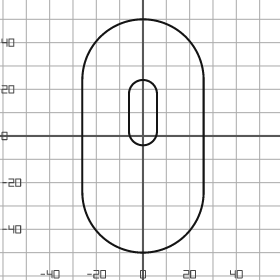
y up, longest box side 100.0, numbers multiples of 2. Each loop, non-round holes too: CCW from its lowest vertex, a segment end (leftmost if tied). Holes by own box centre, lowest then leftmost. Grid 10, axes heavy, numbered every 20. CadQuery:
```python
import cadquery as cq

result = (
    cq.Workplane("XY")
    .moveTo(-26.0, -24.0)
    .threePointArc((0.0, -50.0), (26.0, -24.0))
    .lineTo(26.0, 24.0)
    .threePointArc((0.0, 50.0), (-26.0, 24.0))
    .close()
    .moveTo(-6.0, 2.0)
    .threePointArc((0.0, -4.0), (6.0, 2.0))
    .lineTo(6.0, 18.0)
    .threePointArc((0.0, 24.0), (-6.0, 18.0))
    .close()
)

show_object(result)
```